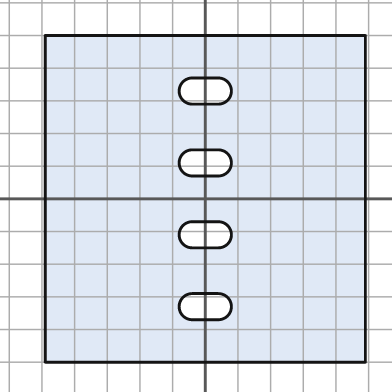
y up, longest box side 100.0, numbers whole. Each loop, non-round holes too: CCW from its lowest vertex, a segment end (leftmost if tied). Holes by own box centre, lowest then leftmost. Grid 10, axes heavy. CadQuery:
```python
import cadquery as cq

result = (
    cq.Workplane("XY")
    .moveTo(-49.0, -50.0)
    .lineTo(49.0, -50.0)
    .lineTo(49.0, 50.0)
    .lineTo(-49.0, 50.0)
    .close()
    .moveTo(-4.0, -37.0)
    .lineTo(4.0, -37.0)
    .threePointArc((8.0, -33.0), (4.0, -29.0))
    .lineTo(-4.0, -29.0)
    .threePointArc((-8.0, -33.0), (-4.0, -37.0))
    .close()
    .moveTo(-4.0, -15.0)
    .lineTo(4.0, -15.0)
    .threePointArc((8.0, -11.0), (4.0, -7.0))
    .lineTo(-4.0, -7.0)
    .threePointArc((-8.0, -11.0), (-4.0, -15.0))
    .close()
    .moveTo(-4.0, 7.0)
    .lineTo(4.0, 7.0)
    .threePointArc((8.0, 11.0), (4.0, 15.0))
    .lineTo(-4.0, 15.0)
    .threePointArc((-8.0, 11.0), (-4.0, 7.0))
    .close()
    .moveTo(-4.0, 29.0)
    .lineTo(4.0, 29.0)
    .threePointArc((8.0, 33.0), (4.0, 37.0))
    .lineTo(-4.0, 37.0)
    .threePointArc((-8.0, 33.0), (-4.0, 29.0))
    .close()
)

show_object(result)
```